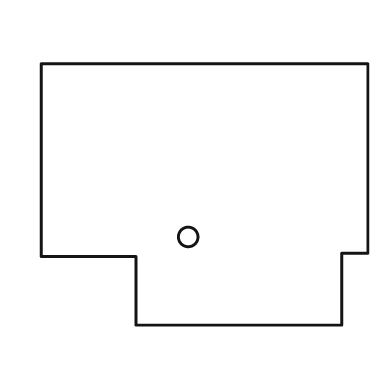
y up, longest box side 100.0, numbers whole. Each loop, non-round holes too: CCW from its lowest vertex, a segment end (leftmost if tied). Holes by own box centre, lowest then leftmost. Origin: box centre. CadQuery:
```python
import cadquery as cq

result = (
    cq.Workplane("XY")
    .moveTo(-21.0, -40.0)
    .lineTo(42.0, -40.0)
    .lineTo(42.0, -18.0)
    .lineTo(50.0, -18.0)
    .lineTo(50.0, 40.0)
    .lineTo(-50.0, 40.0)
    .lineTo(-50.0, -19.0)
    .lineTo(-21.0, -19.0)
    .close()
    .moveTo(-5.0, -13.0)
    .circle(3.0)
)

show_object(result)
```